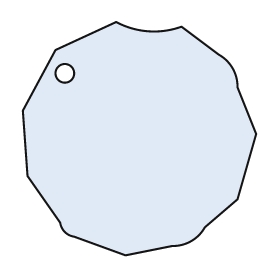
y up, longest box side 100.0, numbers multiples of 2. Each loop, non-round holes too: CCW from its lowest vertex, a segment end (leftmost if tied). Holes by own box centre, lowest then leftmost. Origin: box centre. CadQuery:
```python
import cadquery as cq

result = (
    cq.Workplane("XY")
    .moveTo(-6.0, -50.0)
    .lineTo(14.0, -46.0)
    .threePointArc((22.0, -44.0), (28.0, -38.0))
    .lineTo(42.0, -26.0)
    .lineTo(50.0, 2.0)
    .lineTo(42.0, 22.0)
    .threePointArc((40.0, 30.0), (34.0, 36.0))
    .lineTo(18.0, 48.0)
    .threePointArc((4.0, 46.0), (-10.0, 50.0))
    .lineTo(-36.0, 38.0)
    .lineTo(-50.0, 12.0)
    .lineTo(-48.0, -16.0)
    .lineTo(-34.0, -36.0)
    .threePointArc((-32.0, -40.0), (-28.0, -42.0))
    .close()
    .moveTo(-32.0, 28.0)
    .circle(4.0)
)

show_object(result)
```